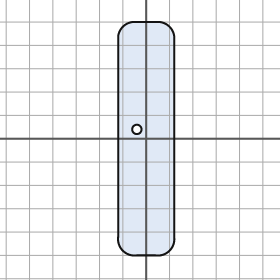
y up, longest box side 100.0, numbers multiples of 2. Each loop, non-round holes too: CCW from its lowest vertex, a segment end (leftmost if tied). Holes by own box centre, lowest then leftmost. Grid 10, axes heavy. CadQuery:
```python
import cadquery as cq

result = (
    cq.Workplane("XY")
    .moveTo(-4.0, -50.0)
    .lineTo(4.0, -50.0)
    .threePointArc((10.0, -48.0), (12.0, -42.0))
    .lineTo(12.0, 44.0)
    .threePointArc((10.0, 48.0), (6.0, 50.0))
    .lineTo(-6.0, 50.0)
    .threePointArc((-10.0, 48.0), (-12.0, 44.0))
    .lineTo(-12.0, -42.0)
    .threePointArc((-10.0, -48.0), (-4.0, -50.0))
    .close()
    .moveTo(-4.0, 4.0)
    .circle(2.0)
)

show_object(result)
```